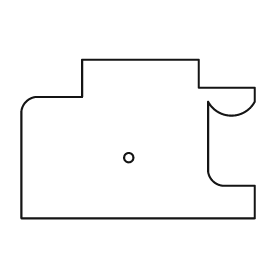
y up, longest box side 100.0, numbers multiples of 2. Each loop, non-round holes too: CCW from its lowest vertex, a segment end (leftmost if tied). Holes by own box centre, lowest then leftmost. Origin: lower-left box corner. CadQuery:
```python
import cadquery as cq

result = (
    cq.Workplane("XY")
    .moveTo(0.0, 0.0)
    .lineTo(100.0, 0.0)
    .lineTo(100.0, 14.0)
    .lineTo(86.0, 14.0)
    .threePointArc((82.0, 16.0), (80.0, 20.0))
    .lineTo(80.0, 50.0)
    .threePointArc((90.0, 44.0), (100.0, 50.0))
    .lineTo(100.0, 56.0)
    .lineTo(76.0, 56.0)
    .lineTo(76.0, 68.0)
    .lineTo(26.0, 68.0)
    .lineTo(26.0, 52.0)
    .lineTo(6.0, 52.0)
    .threePointArc((2.0, 50.0), (0.0, 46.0))
    .close()
    .moveTo(46.0, 26.0)
    .circle(2.0)
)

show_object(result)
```